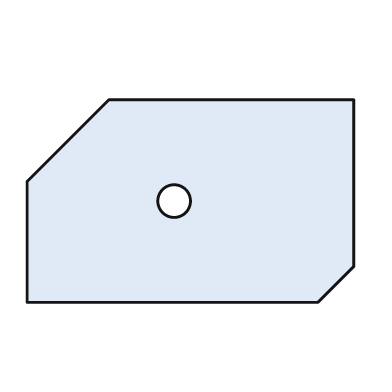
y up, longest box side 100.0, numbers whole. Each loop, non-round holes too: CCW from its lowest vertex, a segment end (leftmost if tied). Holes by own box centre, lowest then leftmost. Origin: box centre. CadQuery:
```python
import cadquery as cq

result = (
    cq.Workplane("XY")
    .moveTo(-50.0, -31.0)
    .lineTo(39.0, -31.0)
    .lineTo(50.0, -20.0)
    .lineTo(50.0, 31.0)
    .lineTo(-25.0, 31.0)
    .lineTo(-50.0, 6.0)
    .close()
    .moveTo(-5.0, 0.0)
    .circle(5.0)
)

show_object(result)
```